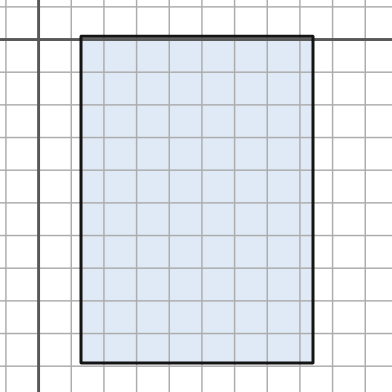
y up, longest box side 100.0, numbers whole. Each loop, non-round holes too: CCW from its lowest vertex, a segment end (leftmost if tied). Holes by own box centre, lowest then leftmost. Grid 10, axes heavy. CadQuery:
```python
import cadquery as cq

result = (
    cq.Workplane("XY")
    .moveTo(13.0, -99.0)
    .lineTo(84.0, -99.0)
    .lineTo(84.0, 1.0)
    .lineTo(13.0, 1.0)
    .close()
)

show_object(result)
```